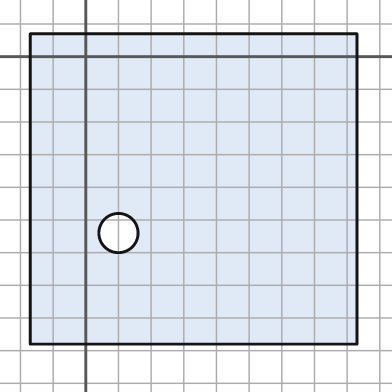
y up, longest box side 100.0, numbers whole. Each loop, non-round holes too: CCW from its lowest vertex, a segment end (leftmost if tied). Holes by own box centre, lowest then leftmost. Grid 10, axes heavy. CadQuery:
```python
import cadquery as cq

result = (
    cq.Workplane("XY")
    .moveTo(-17.0, -88.0)
    .lineTo(83.0, -88.0)
    .lineTo(83.0, 7.0)
    .lineTo(-17.0, 7.0)
    .close()
    .moveTo(10.0, -54.0)
    .circle(6.0)
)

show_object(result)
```